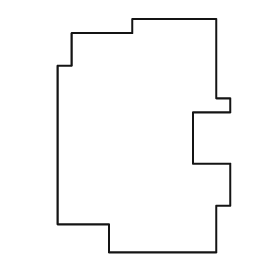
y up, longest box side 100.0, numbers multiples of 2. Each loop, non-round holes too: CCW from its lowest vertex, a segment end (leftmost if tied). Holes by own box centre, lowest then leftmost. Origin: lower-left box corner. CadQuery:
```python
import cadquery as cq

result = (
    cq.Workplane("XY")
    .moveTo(22.0, 0.0)
    .lineTo(68.0, 0.0)
    .lineTo(68.0, 20.0)
    .lineTo(74.0, 20.0)
    .lineTo(74.0, 38.0)
    .lineTo(58.0, 38.0)
    .lineTo(58.0, 60.0)
    .lineTo(74.0, 60.0)
    .lineTo(74.0, 66.0)
    .lineTo(68.0, 66.0)
    .lineTo(68.0, 100.0)
    .lineTo(32.0, 100.0)
    .lineTo(32.0, 94.0)
    .lineTo(6.0, 94.0)
    .lineTo(6.0, 80.0)
    .lineTo(0.0, 80.0)
    .lineTo(0.0, 12.0)
    .lineTo(22.0, 12.0)
    .close()
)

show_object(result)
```